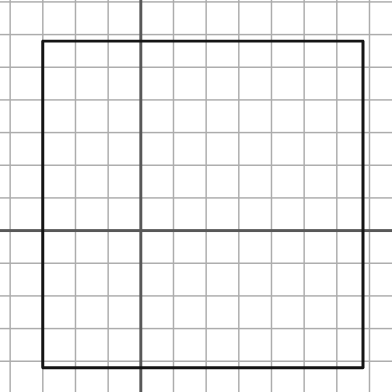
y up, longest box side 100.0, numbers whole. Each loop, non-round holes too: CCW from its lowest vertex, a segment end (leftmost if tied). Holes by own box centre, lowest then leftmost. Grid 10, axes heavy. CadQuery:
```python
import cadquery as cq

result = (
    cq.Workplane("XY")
    .moveTo(-30.0, -42.0)
    .lineTo(68.0, -42.0)
    .lineTo(68.0, 58.0)
    .lineTo(-30.0, 58.0)
    .close()
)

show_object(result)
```